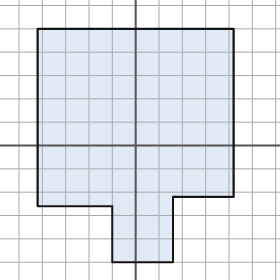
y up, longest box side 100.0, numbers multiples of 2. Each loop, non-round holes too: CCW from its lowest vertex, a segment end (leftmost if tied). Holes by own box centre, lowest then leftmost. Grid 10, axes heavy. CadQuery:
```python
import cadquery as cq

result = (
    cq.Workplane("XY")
    .moveTo(-10.0, -50.0)
    .lineTo(16.0, -50.0)
    .lineTo(16.0, -22.0)
    .lineTo(42.0, -22.0)
    .lineTo(42.0, 50.0)
    .lineTo(-42.0, 50.0)
    .lineTo(-42.0, -26.0)
    .lineTo(-10.0, -26.0)
    .close()
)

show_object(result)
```